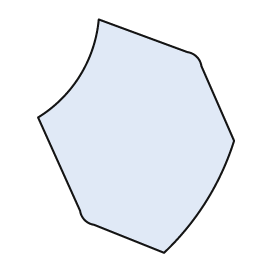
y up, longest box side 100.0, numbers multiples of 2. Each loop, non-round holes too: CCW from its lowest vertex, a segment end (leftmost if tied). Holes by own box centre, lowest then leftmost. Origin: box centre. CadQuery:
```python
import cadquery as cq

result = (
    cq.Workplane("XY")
    .moveTo(12.0, -50.0)
    .threePointArc((30.0, -28.0), (42.0, -2.0))
    .lineTo(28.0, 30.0)
    .threePointArc((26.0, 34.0), (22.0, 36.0))
    .lineTo(-16.0, 50.0)
    .threePointArc((-24.0, 26.0), (-42.0, 8.0))
    .lineTo(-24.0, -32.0)
    .threePointArc((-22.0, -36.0), (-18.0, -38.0))
    .close()
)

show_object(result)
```